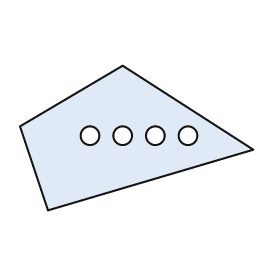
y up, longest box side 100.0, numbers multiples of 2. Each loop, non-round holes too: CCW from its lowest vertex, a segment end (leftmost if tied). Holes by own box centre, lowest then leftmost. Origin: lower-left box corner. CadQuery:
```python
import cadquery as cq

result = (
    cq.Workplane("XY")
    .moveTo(12.0, 0.0)
    .lineTo(100.0, 26.0)
    .lineTo(44.0, 62.0)
    .lineTo(0.0, 36.0)
    .close()
    .moveTo(30.0, 32.0)
    .circle(4.0)
    .moveTo(44.0, 32.0)
    .circle(4.0)
    .moveTo(58.0, 32.0)
    .circle(4.0)
    .moveTo(72.0, 32.0)
    .circle(4.0)
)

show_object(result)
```